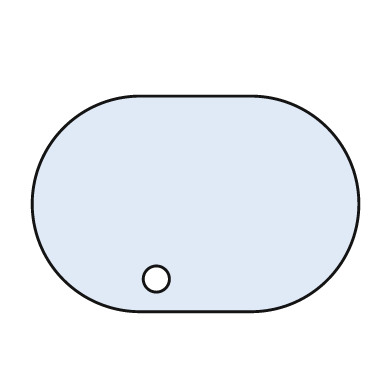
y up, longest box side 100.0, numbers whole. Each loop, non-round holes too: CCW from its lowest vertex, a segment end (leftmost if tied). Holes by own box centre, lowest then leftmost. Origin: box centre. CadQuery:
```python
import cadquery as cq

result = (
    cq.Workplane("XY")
    .moveTo(-17.0, -33.0)
    .lineTo(17.0, -33.0)
    .threePointArc((50.0, 0.0), (17.0, 33.0))
    .lineTo(-17.0, 33.0)
    .threePointArc((-50.0, 0.0), (-17.0, -33.0))
    .close()
    .moveTo(-12.0, -23.0)
    .circle(4.0)
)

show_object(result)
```